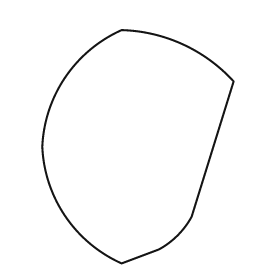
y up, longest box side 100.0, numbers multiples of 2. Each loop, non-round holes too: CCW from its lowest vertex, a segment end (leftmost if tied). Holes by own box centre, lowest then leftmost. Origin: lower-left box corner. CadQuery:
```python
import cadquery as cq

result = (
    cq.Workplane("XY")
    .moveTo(34.0, 0.0)
    .lineTo(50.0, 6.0)
    .threePointArc((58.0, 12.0), (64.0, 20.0))
    .lineTo(82.0, 78.0)
    .threePointArc((60.0, 94.0), (34.0, 100.0))
    .threePointArc((10.0, 80.0), (0.0, 50.0))
    .threePointArc((10.0, 20.0), (34.0, 0.0))
    .close()
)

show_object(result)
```